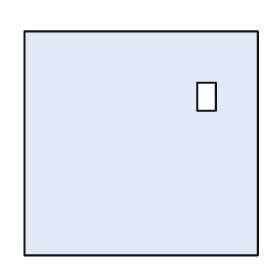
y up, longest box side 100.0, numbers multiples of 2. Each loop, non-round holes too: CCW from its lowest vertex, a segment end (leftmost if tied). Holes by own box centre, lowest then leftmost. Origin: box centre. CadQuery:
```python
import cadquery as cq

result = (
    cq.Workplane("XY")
    .moveTo(-50.0, -48.0)
    .lineTo(50.0, -48.0)
    .lineTo(50.0, 48.0)
    .lineTo(-50.0, 48.0)
    .close()
    .moveTo(24.0, 14.0)
    .lineTo(32.0, 14.0)
    .lineTo(32.0, 26.0)
    .lineTo(24.0, 26.0)
    .close()
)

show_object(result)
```